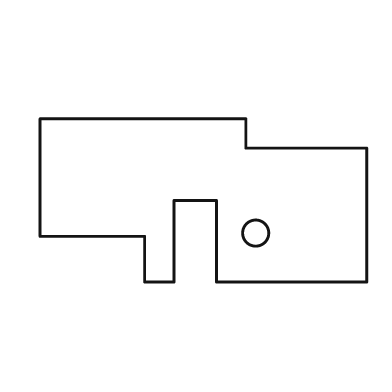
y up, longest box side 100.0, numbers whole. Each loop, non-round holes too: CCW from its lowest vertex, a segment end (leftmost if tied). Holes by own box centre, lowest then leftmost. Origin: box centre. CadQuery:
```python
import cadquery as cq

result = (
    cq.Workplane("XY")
    .moveTo(-18.0, -25.0)
    .lineTo(-9.0, -25.0)
    .lineTo(-9.0, 0.0)
    .lineTo(4.0, 0.0)
    .lineTo(4.0, -25.0)
    .lineTo(50.0, -25.0)
    .lineTo(50.0, 16.0)
    .lineTo(13.0, 16.0)
    .lineTo(13.0, 25.0)
    .lineTo(-50.0, 25.0)
    .lineTo(-50.0, -11.0)
    .lineTo(-18.0, -11.0)
    .close()
    .moveTo(16.0, -10.0)
    .circle(4.0)
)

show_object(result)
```